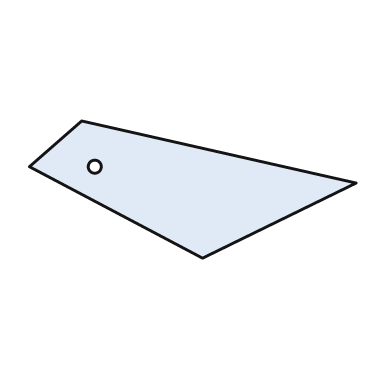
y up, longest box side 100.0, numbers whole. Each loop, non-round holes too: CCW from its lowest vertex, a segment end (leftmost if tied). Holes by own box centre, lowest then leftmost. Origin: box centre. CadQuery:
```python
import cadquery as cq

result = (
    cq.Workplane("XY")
    .moveTo(3.0, -21.0)
    .lineTo(50.0, 2.0)
    .lineTo(-34.0, 21.0)
    .lineTo(-50.0, 7.0)
    .close()
    .moveTo(-30.0, 7.0)
    .circle(2.0)
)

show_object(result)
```